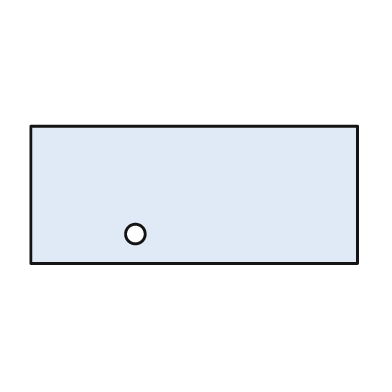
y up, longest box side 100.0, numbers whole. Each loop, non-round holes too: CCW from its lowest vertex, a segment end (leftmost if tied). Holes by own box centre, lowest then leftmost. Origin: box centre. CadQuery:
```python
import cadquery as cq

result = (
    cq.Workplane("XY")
    .moveTo(-50.0, -21.0)
    .lineTo(50.0, -21.0)
    .lineTo(50.0, 21.0)
    .lineTo(-50.0, 21.0)
    .close()
    .moveTo(-18.0, -12.0)
    .circle(3.0)
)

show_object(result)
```